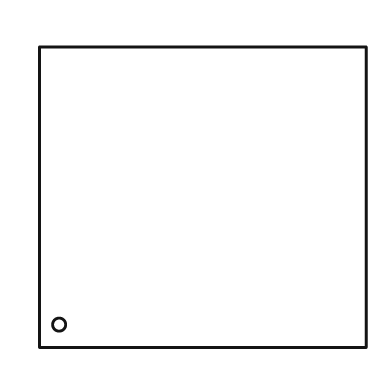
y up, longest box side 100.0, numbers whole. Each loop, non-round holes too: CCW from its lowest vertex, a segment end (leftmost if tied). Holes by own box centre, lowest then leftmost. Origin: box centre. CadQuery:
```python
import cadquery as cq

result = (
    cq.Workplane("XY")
    .moveTo(-50.0, -46.0)
    .lineTo(50.0, -46.0)
    .lineTo(50.0, 46.0)
    .lineTo(-50.0, 46.0)
    .close()
    .moveTo(-44.0, -39.0)
    .circle(2.0)
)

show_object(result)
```